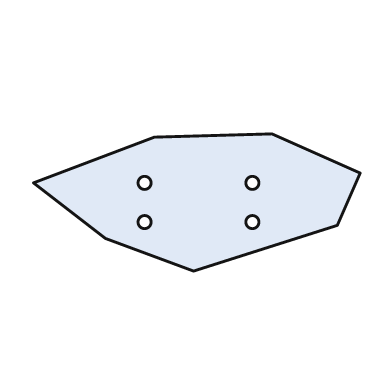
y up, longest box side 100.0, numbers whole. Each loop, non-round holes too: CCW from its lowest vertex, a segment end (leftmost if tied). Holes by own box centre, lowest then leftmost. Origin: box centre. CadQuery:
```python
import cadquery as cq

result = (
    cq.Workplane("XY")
    .moveTo(-1.0, -21.0)
    .lineTo(43.0, -7.0)
    .lineTo(50.0, 9.0)
    .lineTo(23.0, 21.0)
    .lineTo(-13.0, 20.0)
    .lineTo(-50.0, 6.0)
    .lineTo(-28.0, -11.0)
    .close()
    .moveTo(-16.0, -6.0)
    .circle(2.0)
    .moveTo(17.0, -6.0)
    .circle(2.0)
    .moveTo(-16.0, 6.0)
    .circle(2.0)
    .moveTo(17.0, 6.0)
    .circle(2.0)
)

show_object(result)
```